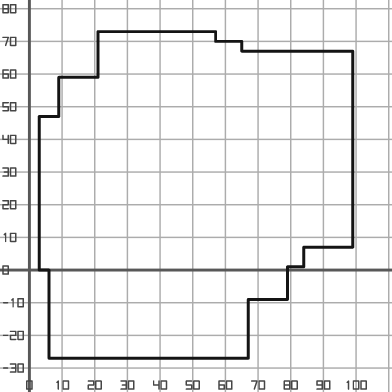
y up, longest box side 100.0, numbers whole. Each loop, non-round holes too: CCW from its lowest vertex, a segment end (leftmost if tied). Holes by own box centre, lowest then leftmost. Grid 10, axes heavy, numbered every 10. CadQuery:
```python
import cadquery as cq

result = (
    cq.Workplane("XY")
    .moveTo(6.0, -27.0)
    .lineTo(67.0, -27.0)
    .lineTo(67.0, -9.0)
    .lineTo(79.0, -9.0)
    .lineTo(79.0, 1.0)
    .lineTo(84.0, 1.0)
    .lineTo(84.0, 7.0)
    .lineTo(99.0, 7.0)
    .lineTo(99.0, 67.0)
    .lineTo(65.0, 67.0)
    .lineTo(65.0, 70.0)
    .lineTo(57.0, 70.0)
    .lineTo(57.0, 73.0)
    .lineTo(21.0, 73.0)
    .lineTo(21.0, 59.0)
    .lineTo(9.0, 59.0)
    .lineTo(9.0, 47.0)
    .lineTo(3.0, 47.0)
    .lineTo(3.0, 0.0)
    .lineTo(6.0, 0.0)
    .close()
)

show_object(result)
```